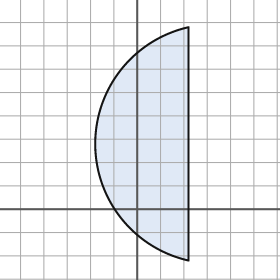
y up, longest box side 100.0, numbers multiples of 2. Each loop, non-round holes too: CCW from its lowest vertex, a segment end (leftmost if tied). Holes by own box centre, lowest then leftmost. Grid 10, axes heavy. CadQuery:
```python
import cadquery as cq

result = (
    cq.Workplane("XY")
    .moveTo(22.0, -22.0)
    .lineTo(22.0, 78.0)
    .threePointArc((-18.0, 28.0), (22.0, -22.0))
    .close()
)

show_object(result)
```